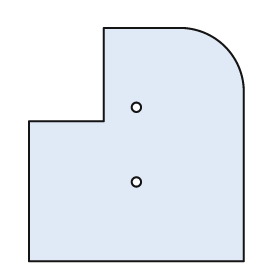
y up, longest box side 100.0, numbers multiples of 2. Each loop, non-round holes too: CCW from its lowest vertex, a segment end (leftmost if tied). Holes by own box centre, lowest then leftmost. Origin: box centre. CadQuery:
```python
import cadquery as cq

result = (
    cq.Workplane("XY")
    .moveTo(-46.0, -50.0)
    .lineTo(46.0, -50.0)
    .lineTo(46.0, 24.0)
    .threePointArc((38.0, 42.0), (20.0, 50.0))
    .lineTo(-14.0, 50.0)
    .lineTo(-14.0, 10.0)
    .lineTo(-46.0, 10.0)
    .close()
    .moveTo(0.0, -16.0)
    .circle(2.0)
    .moveTo(0.0, 16.0)
    .circle(2.0)
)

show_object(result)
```